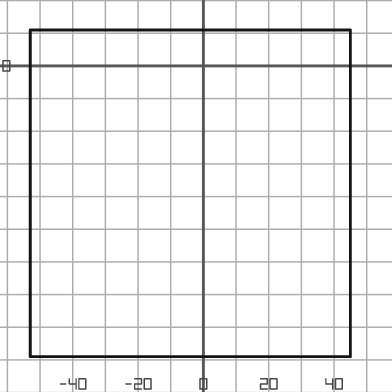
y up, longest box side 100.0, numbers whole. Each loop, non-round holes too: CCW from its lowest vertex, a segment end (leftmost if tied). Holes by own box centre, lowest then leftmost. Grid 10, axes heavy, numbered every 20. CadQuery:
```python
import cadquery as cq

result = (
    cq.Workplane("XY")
    .moveTo(-53.0, -89.0)
    .lineTo(45.0, -89.0)
    .lineTo(45.0, 11.0)
    .lineTo(-53.0, 11.0)
    .close()
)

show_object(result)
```